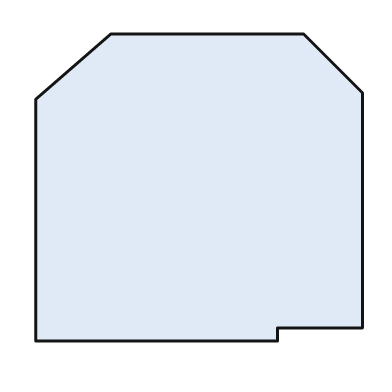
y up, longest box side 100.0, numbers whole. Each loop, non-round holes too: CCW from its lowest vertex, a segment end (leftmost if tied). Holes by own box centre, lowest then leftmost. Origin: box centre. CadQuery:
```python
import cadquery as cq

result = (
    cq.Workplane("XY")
    .moveTo(-50.0, -47.0)
    .lineTo(24.0, -47.0)
    .lineTo(24.0, -43.0)
    .lineTo(50.0, -43.0)
    .lineTo(50.0, 29.0)
    .lineTo(32.0, 47.0)
    .lineTo(-27.0, 47.0)
    .lineTo(-50.0, 27.0)
    .close()
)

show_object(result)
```